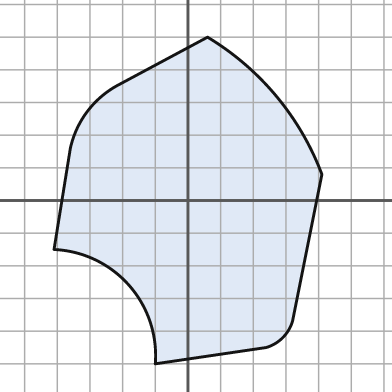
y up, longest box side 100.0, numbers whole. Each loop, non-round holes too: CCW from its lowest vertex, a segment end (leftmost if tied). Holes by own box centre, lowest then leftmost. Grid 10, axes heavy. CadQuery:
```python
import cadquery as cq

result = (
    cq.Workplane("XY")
    .moveTo(-10.0, -50.0)
    .lineTo(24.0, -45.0)
    .threePointArc((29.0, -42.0), (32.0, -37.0))
    .lineTo(41.0, 8.0)
    .threePointArc((27.0, 32.0), (6.0, 50.0))
    .lineTo(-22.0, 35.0)
    .threePointArc((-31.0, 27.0), (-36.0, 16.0))
    .lineTo(-41.0, -15.0)
    .threePointArc((-18.0, -26.0), (-10.0, -50.0))
    .close()
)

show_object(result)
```